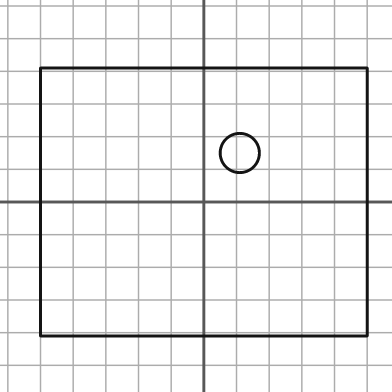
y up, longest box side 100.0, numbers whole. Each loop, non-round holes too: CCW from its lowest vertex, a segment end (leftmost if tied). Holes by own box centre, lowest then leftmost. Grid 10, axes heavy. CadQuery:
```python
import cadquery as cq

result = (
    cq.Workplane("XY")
    .moveTo(-50.0, -41.0)
    .lineTo(50.0, -41.0)
    .lineTo(50.0, 41.0)
    .lineTo(-50.0, 41.0)
    .close()
    .moveTo(11.0, 15.0)
    .circle(6.0)
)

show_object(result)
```